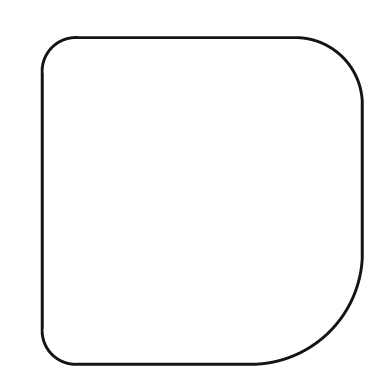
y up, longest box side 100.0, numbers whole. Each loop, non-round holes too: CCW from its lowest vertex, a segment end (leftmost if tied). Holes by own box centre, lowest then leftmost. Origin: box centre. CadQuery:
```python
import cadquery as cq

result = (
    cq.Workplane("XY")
    .moveTo(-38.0, -50.0)
    .lineTo(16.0, -50.0)
    .threePointArc((39.0, -40.0), (49.0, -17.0))
    .lineTo(49.0, 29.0)
    .threePointArc((43.0, 44.0), (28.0, 50.0))
    .lineTo(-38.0, 50.0)
    .threePointArc((-46.0, 47.0), (-49.0, 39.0))
    .lineTo(-49.0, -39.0)
    .threePointArc((-46.0, -47.0), (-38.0, -50.0))
    .close()
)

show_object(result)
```